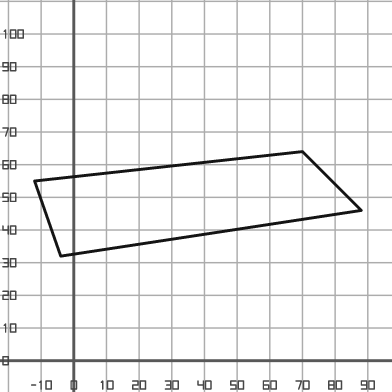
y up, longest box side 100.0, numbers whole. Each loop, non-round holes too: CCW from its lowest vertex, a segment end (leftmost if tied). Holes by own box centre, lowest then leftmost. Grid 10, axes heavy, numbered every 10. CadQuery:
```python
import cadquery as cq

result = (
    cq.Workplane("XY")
    .moveTo(-4.0, 32.0)
    .lineTo(88.0, 46.0)
    .lineTo(70.0, 64.0)
    .lineTo(-12.0, 55.0)
    .close()
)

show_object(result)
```